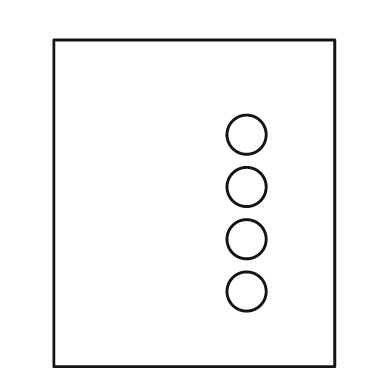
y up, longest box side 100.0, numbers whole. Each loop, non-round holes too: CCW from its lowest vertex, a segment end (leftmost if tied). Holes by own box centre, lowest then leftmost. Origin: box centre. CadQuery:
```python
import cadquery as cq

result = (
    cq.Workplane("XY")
    .moveTo(-43.0, -50.0)
    .lineTo(43.0, -50.0)
    .lineTo(43.0, 50.0)
    .lineTo(-43.0, 50.0)
    .close()
    .moveTo(16.0, -27.0)
    .circle(6.0)
    .moveTo(16.0, -11.0)
    .circle(6.0)
    .moveTo(16.0, 5.0)
    .circle(6.0)
    .moveTo(16.0, 21.0)
    .circle(6.0)
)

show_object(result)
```